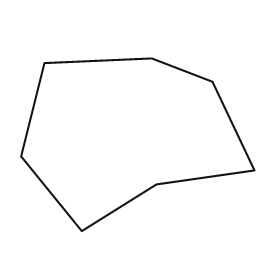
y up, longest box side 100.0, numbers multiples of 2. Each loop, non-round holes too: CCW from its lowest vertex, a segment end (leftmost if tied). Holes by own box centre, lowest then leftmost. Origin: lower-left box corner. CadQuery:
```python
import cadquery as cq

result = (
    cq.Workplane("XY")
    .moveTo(26.0, 0.0)
    .lineTo(58.0, 20.0)
    .lineTo(100.0, 26.0)
    .lineTo(82.0, 64.0)
    .lineTo(56.0, 74.0)
    .lineTo(10.0, 72.0)
    .lineTo(0.0, 32.0)
    .close()
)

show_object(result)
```